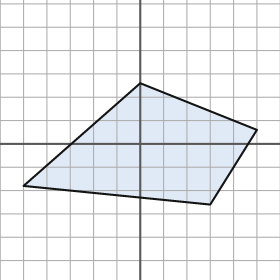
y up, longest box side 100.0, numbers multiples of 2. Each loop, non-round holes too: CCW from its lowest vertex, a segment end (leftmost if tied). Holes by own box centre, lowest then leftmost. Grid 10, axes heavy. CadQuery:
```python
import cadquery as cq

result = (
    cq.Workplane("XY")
    .moveTo(30.0, -26.0)
    .lineTo(50.0, 6.0)
    .lineTo(0.0, 26.0)
    .lineTo(-50.0, -18.0)
    .close()
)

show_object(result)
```